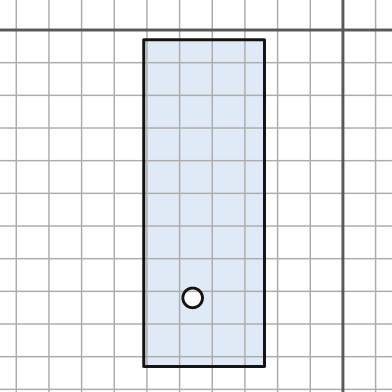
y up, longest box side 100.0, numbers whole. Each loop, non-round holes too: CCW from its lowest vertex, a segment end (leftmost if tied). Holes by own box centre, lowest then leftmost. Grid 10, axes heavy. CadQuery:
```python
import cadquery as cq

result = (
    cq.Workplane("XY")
    .moveTo(-61.0, -103.0)
    .lineTo(-24.0, -103.0)
    .lineTo(-24.0, -3.0)
    .lineTo(-61.0, -3.0)
    .close()
    .moveTo(-46.0, -82.0)
    .circle(3.0)
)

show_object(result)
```